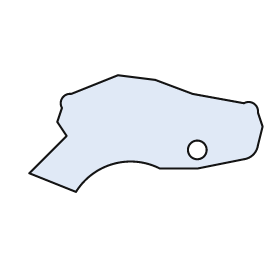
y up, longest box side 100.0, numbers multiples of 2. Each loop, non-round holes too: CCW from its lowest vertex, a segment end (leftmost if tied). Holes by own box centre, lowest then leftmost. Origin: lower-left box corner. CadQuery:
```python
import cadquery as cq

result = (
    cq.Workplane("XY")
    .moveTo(20.0, 0.0)
    .threePointArc((36.0, 12.0), (56.0, 10.0))
    .lineTo(72.0, 10.0)
    .lineTo(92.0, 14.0)
    .threePointArc((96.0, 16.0), (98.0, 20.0))
    .lineTo(100.0, 28.0)
    .lineTo(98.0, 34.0)
    .threePointArc((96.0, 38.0), (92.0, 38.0))
    .lineTo(70.0, 42.0)
    .lineTo(54.0, 48.0)
    .lineTo(38.0, 50.0)
    .lineTo(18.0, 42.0)
    .threePointArc((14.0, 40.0), (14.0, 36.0))
    .lineTo(12.0, 30.0)
    .lineTo(16.0, 24.0)
    .lineTo(0.0, 8.0)
    .close()
    .moveTo(72.0, 18.0)
    .circle(4.0)
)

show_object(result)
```